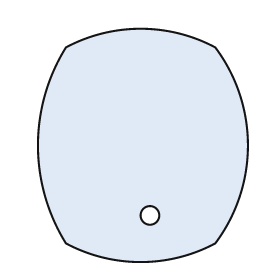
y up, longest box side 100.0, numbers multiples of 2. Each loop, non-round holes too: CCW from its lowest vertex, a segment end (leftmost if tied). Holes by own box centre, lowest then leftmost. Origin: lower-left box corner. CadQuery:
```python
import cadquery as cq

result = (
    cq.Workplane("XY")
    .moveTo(12.0, 8.0)
    .threePointArc((44.0, 0.0), (76.0, 8.0))
    .threePointArc((90.0, 50.0), (76.0, 92.0))
    .threePointArc((44.0, 100.0), (12.0, 92.0))
    .threePointArc((0.0, 50.0), (12.0, 8.0))
    .close()
    .moveTo(48.0, 20.0)
    .circle(4.0)
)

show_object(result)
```